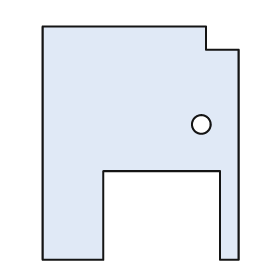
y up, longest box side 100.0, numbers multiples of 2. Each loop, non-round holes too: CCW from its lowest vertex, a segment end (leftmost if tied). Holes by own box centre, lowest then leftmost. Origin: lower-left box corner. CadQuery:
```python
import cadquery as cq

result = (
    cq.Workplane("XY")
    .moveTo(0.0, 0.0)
    .lineTo(26.0, 0.0)
    .lineTo(26.0, 38.0)
    .lineTo(76.0, 38.0)
    .lineTo(76.0, 0.0)
    .lineTo(84.0, 0.0)
    .lineTo(84.0, 90.0)
    .lineTo(70.0, 90.0)
    .lineTo(70.0, 100.0)
    .lineTo(0.0, 100.0)
    .close()
    .moveTo(68.0, 58.0)
    .circle(4.0)
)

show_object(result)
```